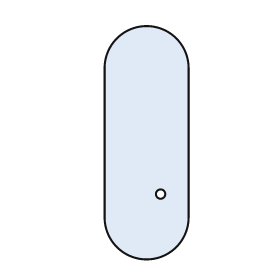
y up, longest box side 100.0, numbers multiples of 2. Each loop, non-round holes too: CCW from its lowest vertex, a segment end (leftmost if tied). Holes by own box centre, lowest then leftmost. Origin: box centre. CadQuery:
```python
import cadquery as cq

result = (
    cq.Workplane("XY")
    .moveTo(-18.0, -32.0)
    .threePointArc((0.0, -50.0), (18.0, -32.0))
    .lineTo(18.0, 32.0)
    .threePointArc((0.0, 50.0), (-18.0, 32.0))
    .close()
    .moveTo(6.0, -22.0)
    .circle(2.0)
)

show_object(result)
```